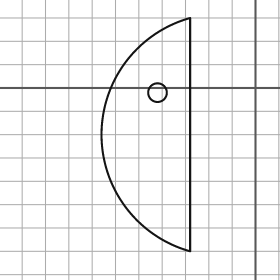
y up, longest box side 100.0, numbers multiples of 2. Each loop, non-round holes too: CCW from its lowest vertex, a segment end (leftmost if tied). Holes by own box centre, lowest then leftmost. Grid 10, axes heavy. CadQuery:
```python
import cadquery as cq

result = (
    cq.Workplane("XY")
    .moveTo(-28.0, -70.0)
    .lineTo(-28.0, 30.0)
    .threePointArc((-66.0, -20.0), (-28.0, -70.0))
    .close()
    .moveTo(-42.0, -2.0)
    .circle(4.0)
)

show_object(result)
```